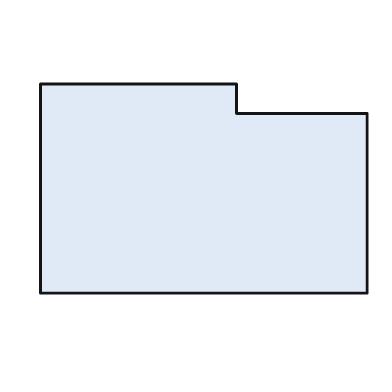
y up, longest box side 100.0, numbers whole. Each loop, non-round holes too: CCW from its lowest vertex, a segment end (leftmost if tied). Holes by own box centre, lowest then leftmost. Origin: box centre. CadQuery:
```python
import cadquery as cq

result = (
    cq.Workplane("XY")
    .moveTo(-50.0, -32.0)
    .lineTo(50.0, -32.0)
    .lineTo(50.0, 23.0)
    .lineTo(10.0, 23.0)
    .lineTo(10.0, 32.0)
    .lineTo(-50.0, 32.0)
    .close()
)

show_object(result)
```